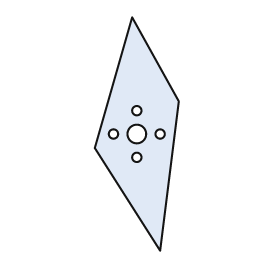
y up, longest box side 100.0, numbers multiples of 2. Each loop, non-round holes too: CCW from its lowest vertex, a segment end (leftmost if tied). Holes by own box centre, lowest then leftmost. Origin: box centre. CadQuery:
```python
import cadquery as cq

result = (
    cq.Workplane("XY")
    .moveTo(10.0, -50.0)
    .lineTo(18.0, 14.0)
    .lineTo(-2.0, 50.0)
    .lineTo(-18.0, -6.0)
    .close()
    .moveTo(0.0, -10.0)
    .circle(2.0)
    .moveTo(-10.0, 0.0)
    .circle(2.0)
    .moveTo(0.0, 0.0)
    .circle(4.0)
    .moveTo(10.0, 0.0)
    .circle(2.0)
    .moveTo(0.0, 10.0)
    .circle(2.0)
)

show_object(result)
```